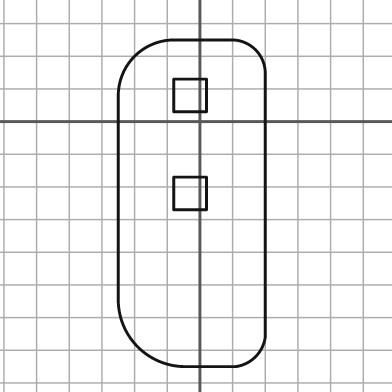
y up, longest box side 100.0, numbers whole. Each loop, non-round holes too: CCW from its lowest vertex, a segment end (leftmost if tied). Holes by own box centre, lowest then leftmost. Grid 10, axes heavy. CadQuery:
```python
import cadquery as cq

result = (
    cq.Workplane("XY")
    .moveTo(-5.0, -75.0)
    .lineTo(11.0, -75.0)
    .threePointArc((17.0, -72.0), (20.0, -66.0))
    .lineTo(20.0, 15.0)
    .threePointArc((17.0, 22.0), (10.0, 25.0))
    .lineTo(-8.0, 25.0)
    .threePointArc((-20.0, 20.0), (-25.0, 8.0))
    .lineTo(-25.0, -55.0)
    .threePointArc((-19.0, -69.0), (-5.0, -75.0))
    .close()
    .moveTo(-8.0, -27.0)
    .lineTo(2.0, -27.0)
    .lineTo(2.0, -17.0)
    .lineTo(-8.0, -17.0)
    .close()
    .moveTo(-8.0, 3.0)
    .lineTo(2.0, 3.0)
    .lineTo(2.0, 13.0)
    .lineTo(-8.0, 13.0)
    .close()
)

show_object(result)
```